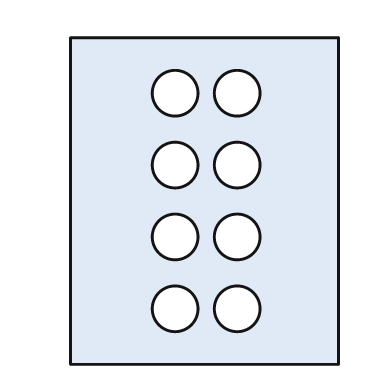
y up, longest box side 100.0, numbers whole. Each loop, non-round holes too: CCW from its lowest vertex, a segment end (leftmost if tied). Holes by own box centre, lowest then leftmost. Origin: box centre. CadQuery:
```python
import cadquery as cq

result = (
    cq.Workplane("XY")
    .moveTo(-41.0, -50.0)
    .lineTo(41.0, -50.0)
    .lineTo(41.0, 50.0)
    .lineTo(-41.0, 50.0)
    .close()
    .moveTo(-9.0, -33.0)
    .circle(7.0)
    .moveTo(10.0, -33.0)
    .circle(7.0)
    .moveTo(-9.0, -11.0)
    .circle(7.0)
    .moveTo(10.0, -11.0)
    .circle(7.0)
    .moveTo(-9.0, 11.0)
    .circle(7.0)
    .moveTo(10.0, 11.0)
    .circle(7.0)
    .moveTo(-9.0, 33.0)
    .circle(7.0)
    .moveTo(10.0, 33.0)
    .circle(7.0)
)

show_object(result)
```